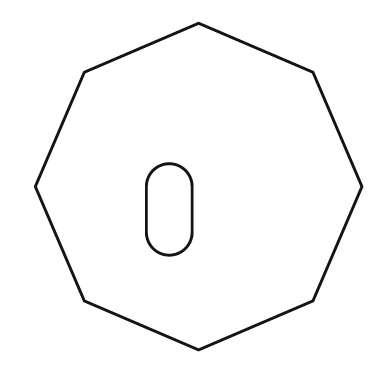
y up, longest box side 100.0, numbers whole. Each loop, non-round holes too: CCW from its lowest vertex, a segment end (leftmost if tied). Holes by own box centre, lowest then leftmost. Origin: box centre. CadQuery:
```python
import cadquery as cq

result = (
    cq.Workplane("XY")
    .moveTo(0.0, -50.0)
    .lineTo(35.0, -35.0)
    .lineTo(50.0, 0.0)
    .lineTo(35.0, 35.0)
    .lineTo(0.0, 50.0)
    .lineTo(-35.0, 35.0)
    .lineTo(-50.0, 0.0)
    .lineTo(-35.0, -35.0)
    .close()
    .moveTo(-16.0, -14.0)
    .threePointArc((-9.0, -21.0), (-2.0, -14.0))
    .lineTo(-2.0, 0.0)
    .threePointArc((-9.0, 7.0), (-16.0, 0.0))
    .close()
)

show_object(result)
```